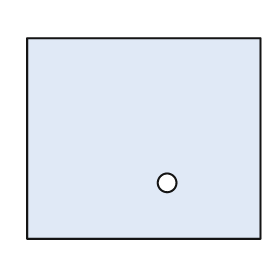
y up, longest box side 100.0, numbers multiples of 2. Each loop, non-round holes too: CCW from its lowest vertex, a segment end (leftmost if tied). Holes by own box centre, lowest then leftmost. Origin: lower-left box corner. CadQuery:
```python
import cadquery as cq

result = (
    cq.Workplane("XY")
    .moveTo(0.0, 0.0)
    .lineTo(100.0, 0.0)
    .lineTo(100.0, 86.0)
    .lineTo(0.0, 86.0)
    .close()
    .moveTo(60.0, 24.0)
    .circle(4.0)
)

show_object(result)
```